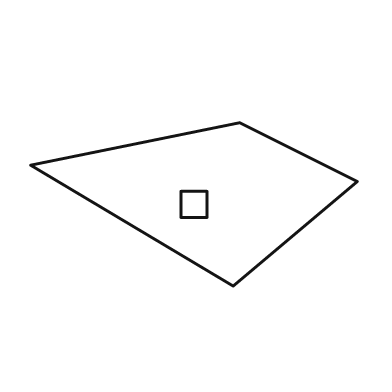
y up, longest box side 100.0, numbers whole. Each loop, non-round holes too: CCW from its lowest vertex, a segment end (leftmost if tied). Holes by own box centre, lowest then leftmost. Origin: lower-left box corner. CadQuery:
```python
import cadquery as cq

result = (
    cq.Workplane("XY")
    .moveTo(62.0, 0.0)
    .lineTo(100.0, 32.0)
    .lineTo(64.0, 50.0)
    .lineTo(0.0, 37.0)
    .close()
    .moveTo(46.0, 21.0)
    .lineTo(54.0, 21.0)
    .lineTo(54.0, 29.0)
    .lineTo(46.0, 29.0)
    .close()
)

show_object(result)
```